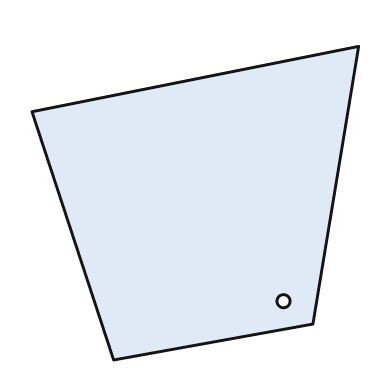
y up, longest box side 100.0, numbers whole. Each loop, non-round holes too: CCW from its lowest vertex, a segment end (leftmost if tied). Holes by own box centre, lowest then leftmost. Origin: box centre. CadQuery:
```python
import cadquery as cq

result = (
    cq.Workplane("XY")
    .moveTo(-25.0, -48.0)
    .lineTo(36.0, -37.0)
    .lineTo(50.0, 48.0)
    .lineTo(-50.0, 28.0)
    .close()
    .moveTo(27.0, -30.0)
    .circle(2.0)
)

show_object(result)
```